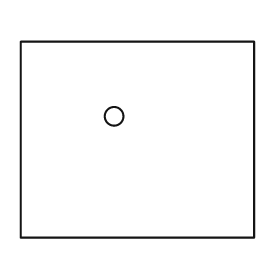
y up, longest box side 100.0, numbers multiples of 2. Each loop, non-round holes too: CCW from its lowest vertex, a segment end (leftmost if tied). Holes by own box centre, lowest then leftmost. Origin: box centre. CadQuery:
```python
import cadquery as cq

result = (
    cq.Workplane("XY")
    .moveTo(-50.0, -42.0)
    .lineTo(50.0, -42.0)
    .lineTo(50.0, 42.0)
    .lineTo(-50.0, 42.0)
    .close()
    .moveTo(-10.0, 10.0)
    .circle(4.0)
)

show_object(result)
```